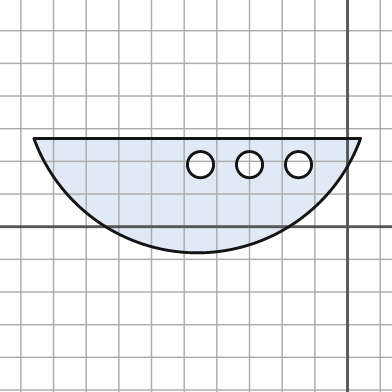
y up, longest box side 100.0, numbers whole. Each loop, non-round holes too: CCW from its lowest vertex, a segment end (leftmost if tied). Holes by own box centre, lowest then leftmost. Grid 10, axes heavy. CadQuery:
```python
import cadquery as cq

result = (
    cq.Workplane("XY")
    .moveTo(-96.0, 27.0)
    .threePointArc((-46.0, -8.0), (4.0, 27.0))
    .close()
    .moveTo(-45.0, 19.0)
    .circle(4.0)
    .moveTo(-30.0, 19.0)
    .circle(4.0)
    .moveTo(-15.0, 19.0)
    .circle(4.0)
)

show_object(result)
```